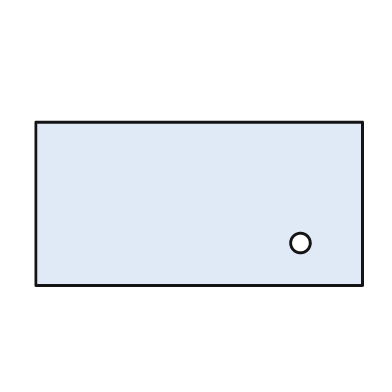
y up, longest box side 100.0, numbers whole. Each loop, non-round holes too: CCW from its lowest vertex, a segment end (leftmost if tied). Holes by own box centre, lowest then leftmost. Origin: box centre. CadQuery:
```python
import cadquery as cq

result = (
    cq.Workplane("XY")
    .moveTo(-50.0, -25.0)
    .lineTo(50.0, -25.0)
    .lineTo(50.0, 25.0)
    .lineTo(-50.0, 25.0)
    .close()
    .moveTo(31.0, -12.0)
    .circle(3.0)
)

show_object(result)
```